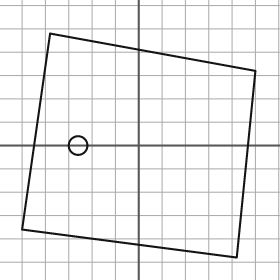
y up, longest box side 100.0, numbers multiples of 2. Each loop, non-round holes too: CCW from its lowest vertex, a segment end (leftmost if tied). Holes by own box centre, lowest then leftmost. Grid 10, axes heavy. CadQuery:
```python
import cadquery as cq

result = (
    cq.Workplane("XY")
    .moveTo(42.0, -48.0)
    .lineTo(50.0, 32.0)
    .lineTo(-38.0, 48.0)
    .lineTo(-50.0, -36.0)
    .close()
    .moveTo(-26.0, 0.0)
    .circle(4.0)
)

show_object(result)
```